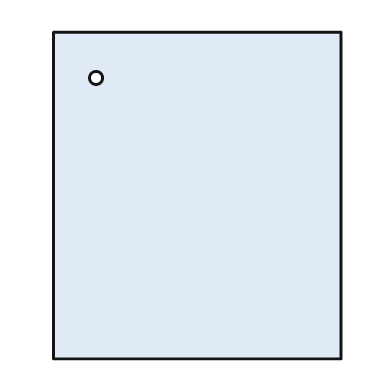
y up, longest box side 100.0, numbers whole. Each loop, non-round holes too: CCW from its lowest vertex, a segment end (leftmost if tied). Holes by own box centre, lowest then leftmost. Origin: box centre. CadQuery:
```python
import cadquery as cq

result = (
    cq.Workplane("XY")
    .moveTo(-44.0, -50.0)
    .lineTo(44.0, -50.0)
    .lineTo(44.0, 50.0)
    .lineTo(-44.0, 50.0)
    .close()
    .moveTo(-31.0, 36.0)
    .circle(2.0)
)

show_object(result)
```